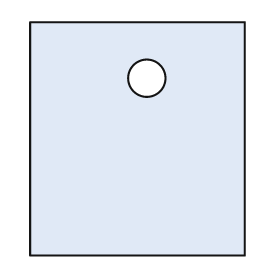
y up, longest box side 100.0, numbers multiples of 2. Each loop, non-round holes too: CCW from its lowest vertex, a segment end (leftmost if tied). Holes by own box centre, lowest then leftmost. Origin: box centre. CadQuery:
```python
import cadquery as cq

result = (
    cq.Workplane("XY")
    .moveTo(-46.0, -50.0)
    .lineTo(46.0, -50.0)
    .lineTo(46.0, 50.0)
    .lineTo(-46.0, 50.0)
    .close()
    .moveTo(4.0, 26.0)
    .circle(8.0)
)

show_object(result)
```